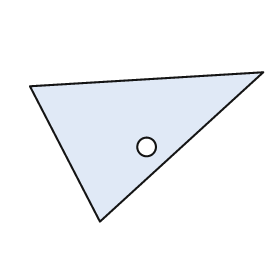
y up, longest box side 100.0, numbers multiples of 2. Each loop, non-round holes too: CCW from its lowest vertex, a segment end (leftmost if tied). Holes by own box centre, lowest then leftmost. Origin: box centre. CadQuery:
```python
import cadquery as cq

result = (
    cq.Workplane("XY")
    .moveTo(-20.0, -32.0)
    .lineTo(50.0, 32.0)
    .lineTo(-50.0, 26.0)
    .close()
    .moveTo(0.0, 0.0)
    .circle(4.0)
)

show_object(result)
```